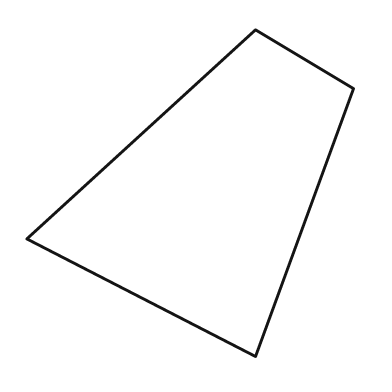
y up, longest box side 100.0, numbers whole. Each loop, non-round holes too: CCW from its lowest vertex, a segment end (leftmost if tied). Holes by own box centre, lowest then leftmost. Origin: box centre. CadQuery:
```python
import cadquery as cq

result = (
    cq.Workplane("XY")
    .moveTo(20.0, -50.0)
    .lineTo(50.0, 32.0)
    .lineTo(20.0, 50.0)
    .lineTo(-50.0, -14.0)
    .close()
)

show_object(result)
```